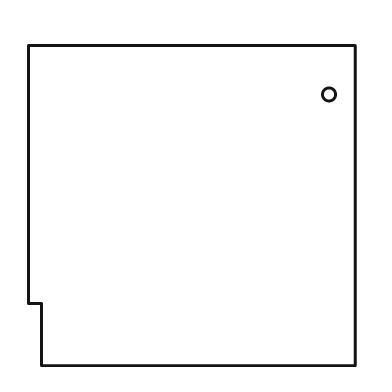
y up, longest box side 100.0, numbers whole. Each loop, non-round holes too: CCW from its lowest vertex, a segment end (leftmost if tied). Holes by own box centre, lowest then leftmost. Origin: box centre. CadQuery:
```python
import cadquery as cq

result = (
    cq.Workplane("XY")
    .moveTo(-46.0, -49.0)
    .lineTo(50.0, -49.0)
    .lineTo(50.0, 49.0)
    .lineTo(-50.0, 49.0)
    .lineTo(-50.0, -30.0)
    .lineTo(-46.0, -30.0)
    .close()
    .moveTo(42.0, 34.0)
    .circle(2.0)
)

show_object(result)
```